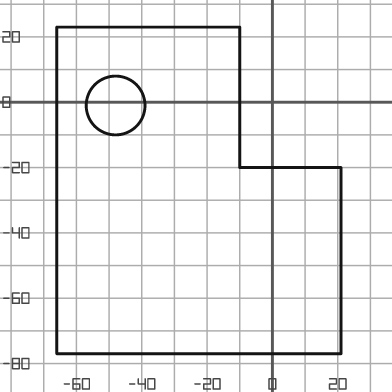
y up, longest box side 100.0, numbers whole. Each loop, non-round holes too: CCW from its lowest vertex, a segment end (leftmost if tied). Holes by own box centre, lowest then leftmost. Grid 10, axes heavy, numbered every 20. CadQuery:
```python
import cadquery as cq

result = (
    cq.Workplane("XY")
    .moveTo(-66.0, -77.0)
    .lineTo(21.0, -77.0)
    .lineTo(21.0, -20.0)
    .lineTo(-10.0, -20.0)
    .lineTo(-10.0, 23.0)
    .lineTo(-66.0, 23.0)
    .close()
    .moveTo(-48.0, -1.0)
    .circle(9.0)
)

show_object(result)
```